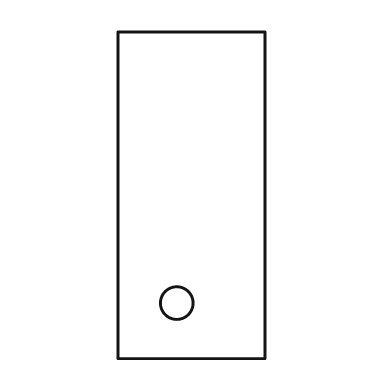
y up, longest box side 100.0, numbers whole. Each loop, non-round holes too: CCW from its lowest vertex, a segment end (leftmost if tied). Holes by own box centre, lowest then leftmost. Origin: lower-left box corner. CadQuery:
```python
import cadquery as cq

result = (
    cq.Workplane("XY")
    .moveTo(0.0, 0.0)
    .lineTo(45.0, 0.0)
    .lineTo(45.0, 100.0)
    .lineTo(0.0, 100.0)
    .close()
    .moveTo(18.0, 17.0)
    .circle(5.0)
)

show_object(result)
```